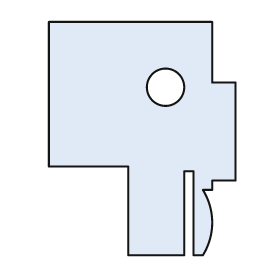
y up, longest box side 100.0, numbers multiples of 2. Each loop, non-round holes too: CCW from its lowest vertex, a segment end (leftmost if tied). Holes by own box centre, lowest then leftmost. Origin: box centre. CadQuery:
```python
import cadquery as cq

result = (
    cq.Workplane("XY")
    .moveTo(-6.0, -50.0)
    .lineTo(18.0, -50.0)
    .lineTo(18.0, -14.0)
    .lineTo(22.0, -14.0)
    .lineTo(22.0, -50.0)
    .lineTo(26.0, -50.0)
    .threePointArc((30.0, -36.0), (26.0, -22.0))
    .lineTo(30.0, -22.0)
    .lineTo(30.0, -18.0)
    .lineTo(40.0, -18.0)
    .lineTo(40.0, 24.0)
    .lineTo(30.0, 24.0)
    .lineTo(30.0, 50.0)
    .lineTo(-40.0, 50.0)
    .lineTo(-40.0, -12.0)
    .lineTo(-6.0, -12.0)
    .close()
    .moveTo(10.0, 22.0)
    .circle(8.0)
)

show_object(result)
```